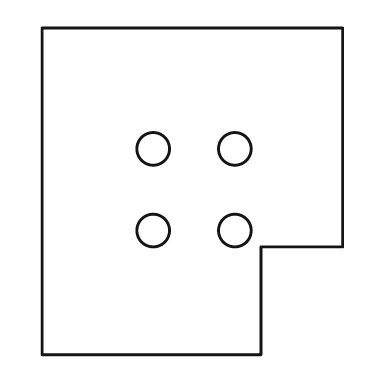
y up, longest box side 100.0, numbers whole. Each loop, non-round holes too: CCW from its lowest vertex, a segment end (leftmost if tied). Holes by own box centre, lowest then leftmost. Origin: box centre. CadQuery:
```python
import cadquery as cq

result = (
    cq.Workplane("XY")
    .moveTo(-46.0, -50.0)
    .lineTo(21.0, -50.0)
    .lineTo(21.0, -17.0)
    .lineTo(46.0, -17.0)
    .lineTo(46.0, 50.0)
    .lineTo(-46.0, 50.0)
    .close()
    .moveTo(-12.0, -12.0)
    .circle(5.0)
    .moveTo(13.0, -12.0)
    .circle(5.0)
    .moveTo(-12.0, 13.0)
    .circle(5.0)
    .moveTo(13.0, 13.0)
    .circle(5.0)
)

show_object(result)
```